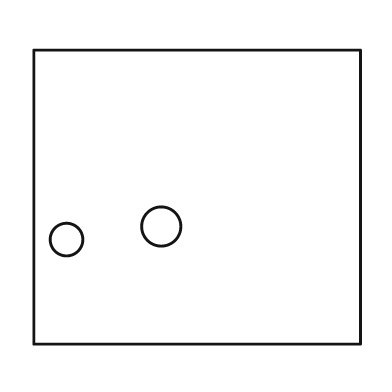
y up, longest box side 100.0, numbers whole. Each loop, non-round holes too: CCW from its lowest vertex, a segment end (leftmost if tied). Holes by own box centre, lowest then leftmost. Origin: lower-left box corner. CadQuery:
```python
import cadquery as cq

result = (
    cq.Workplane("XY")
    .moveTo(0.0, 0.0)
    .lineTo(100.0, 0.0)
    .lineTo(100.0, 90.0)
    .lineTo(0.0, 90.0)
    .close()
    .moveTo(10.0, 32.0)
    .circle(5.0)
    .moveTo(39.0, 36.0)
    .circle(6.0)
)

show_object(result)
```